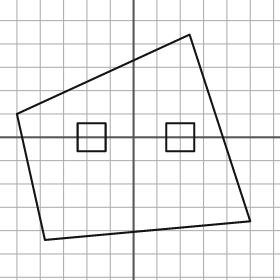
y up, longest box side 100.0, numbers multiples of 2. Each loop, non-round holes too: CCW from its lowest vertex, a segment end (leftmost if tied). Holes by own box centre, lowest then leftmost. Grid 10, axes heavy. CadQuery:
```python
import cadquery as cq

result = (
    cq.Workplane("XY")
    .moveTo(-38.0, -44.0)
    .lineTo(50.0, -36.0)
    .lineTo(24.0, 44.0)
    .lineTo(-50.0, 10.0)
    .close()
    .moveTo(-24.0, -6.0)
    .lineTo(-12.0, -6.0)
    .lineTo(-12.0, 6.0)
    .lineTo(-24.0, 6.0)
    .close()
    .moveTo(14.0, -6.0)
    .lineTo(26.0, -6.0)
    .lineTo(26.0, 6.0)
    .lineTo(14.0, 6.0)
    .close()
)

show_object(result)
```